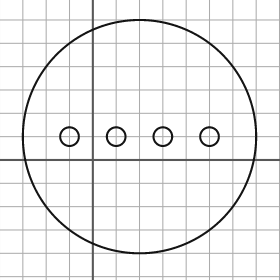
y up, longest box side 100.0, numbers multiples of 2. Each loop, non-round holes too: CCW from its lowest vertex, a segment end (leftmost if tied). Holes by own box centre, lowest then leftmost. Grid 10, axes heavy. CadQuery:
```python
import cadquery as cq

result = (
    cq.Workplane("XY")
    .moveTo(20.0, 10.0)
    .circle(50.0)
    .moveTo(-10.0, 10.0)
    .circle(4.0)
    .moveTo(10.0, 10.0)
    .circle(4.0)
    .moveTo(30.0, 10.0)
    .circle(4.0)
    .moveTo(50.0, 10.0)
    .circle(4.0)
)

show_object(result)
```